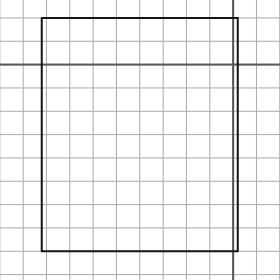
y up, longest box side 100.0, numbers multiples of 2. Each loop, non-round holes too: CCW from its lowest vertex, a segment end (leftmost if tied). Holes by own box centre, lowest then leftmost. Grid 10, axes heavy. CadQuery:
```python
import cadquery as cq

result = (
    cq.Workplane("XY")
    .moveTo(-82.0, -80.0)
    .lineTo(2.0, -80.0)
    .lineTo(2.0, 20.0)
    .lineTo(-82.0, 20.0)
    .close()
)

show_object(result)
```